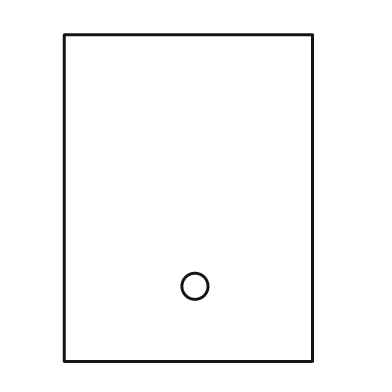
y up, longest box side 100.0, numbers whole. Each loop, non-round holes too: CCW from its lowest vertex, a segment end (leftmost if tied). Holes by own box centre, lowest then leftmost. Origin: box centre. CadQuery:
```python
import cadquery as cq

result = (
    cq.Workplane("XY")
    .moveTo(-38.0, -50.0)
    .lineTo(38.0, -50.0)
    .lineTo(38.0, 50.0)
    .lineTo(-38.0, 50.0)
    .close()
    .moveTo(2.0, -27.0)
    .circle(4.0)
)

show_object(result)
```